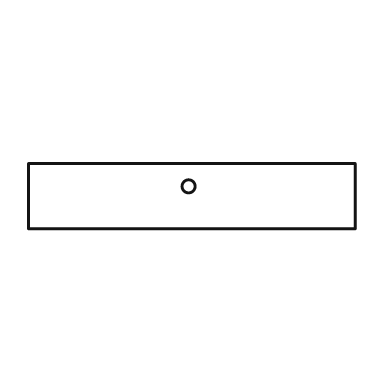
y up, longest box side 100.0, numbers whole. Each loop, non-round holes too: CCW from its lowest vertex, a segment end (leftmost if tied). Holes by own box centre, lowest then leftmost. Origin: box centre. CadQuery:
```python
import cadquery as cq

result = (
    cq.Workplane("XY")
    .moveTo(-50.0, -10.0)
    .lineTo(50.0, -10.0)
    .lineTo(50.0, 10.0)
    .lineTo(-50.0, 10.0)
    .close()
    .moveTo(-1.0, 3.0)
    .circle(2.0)
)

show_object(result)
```